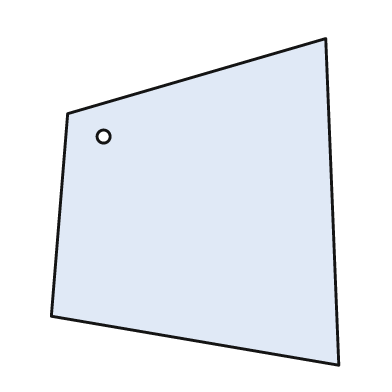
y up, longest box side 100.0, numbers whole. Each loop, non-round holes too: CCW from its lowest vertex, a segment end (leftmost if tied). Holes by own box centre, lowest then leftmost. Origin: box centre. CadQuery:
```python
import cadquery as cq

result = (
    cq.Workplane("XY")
    .moveTo(44.0, -50.0)
    .lineTo(40.0, 50.0)
    .lineTo(-39.0, 27.0)
    .lineTo(-44.0, -35.0)
    .close()
    .moveTo(-28.0, 20.0)
    .circle(2.0)
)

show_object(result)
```